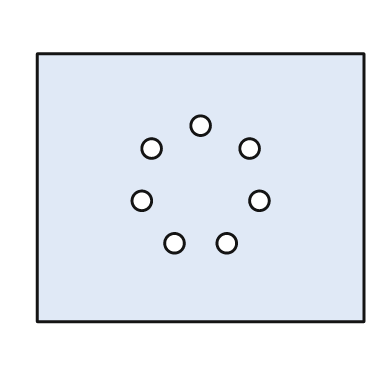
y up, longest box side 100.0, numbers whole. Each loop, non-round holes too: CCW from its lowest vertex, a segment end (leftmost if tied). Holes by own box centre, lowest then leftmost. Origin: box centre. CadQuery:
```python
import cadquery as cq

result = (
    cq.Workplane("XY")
    .moveTo(-50.0, -41.0)
    .lineTo(50.0, -41.0)
    .lineTo(50.0, 41.0)
    .lineTo(-50.0, 41.0)
    .close()
    .moveTo(-8.0, -17.0)
    .circle(3.0)
    .moveTo(8.0, -17.0)
    .circle(3.0)
    .moveTo(-18.0, -4.0)
    .circle(3.0)
    .moveTo(18.0, -4.0)
    .circle(3.0)
    .moveTo(-15.0, 12.0)
    .circle(3.0)
    .moveTo(15.0, 12.0)
    .circle(3.0)
    .moveTo(0.0, 19.0)
    .circle(3.0)
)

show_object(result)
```